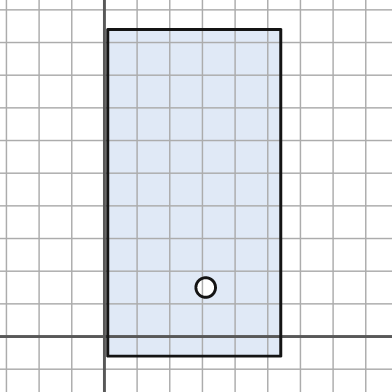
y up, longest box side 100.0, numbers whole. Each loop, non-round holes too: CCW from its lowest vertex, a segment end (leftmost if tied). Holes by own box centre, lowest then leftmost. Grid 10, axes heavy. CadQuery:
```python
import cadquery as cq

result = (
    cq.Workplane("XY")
    .moveTo(1.0, -6.0)
    .lineTo(54.0, -6.0)
    .lineTo(54.0, 94.0)
    .lineTo(1.0, 94.0)
    .close()
    .moveTo(31.0, 15.0)
    .circle(3.0)
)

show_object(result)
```